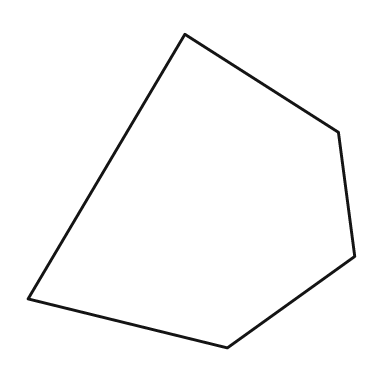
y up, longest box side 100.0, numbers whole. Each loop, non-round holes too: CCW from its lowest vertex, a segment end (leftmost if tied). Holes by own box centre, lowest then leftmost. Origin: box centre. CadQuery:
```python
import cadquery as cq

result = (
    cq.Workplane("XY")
    .moveTo(11.0, -48.0)
    .lineTo(50.0, -20.0)
    .lineTo(45.0, 18.0)
    .lineTo(-2.0, 48.0)
    .lineTo(-50.0, -33.0)
    .close()
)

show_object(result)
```